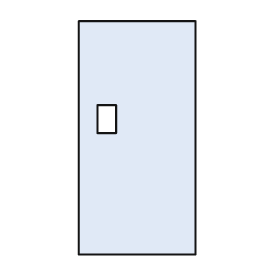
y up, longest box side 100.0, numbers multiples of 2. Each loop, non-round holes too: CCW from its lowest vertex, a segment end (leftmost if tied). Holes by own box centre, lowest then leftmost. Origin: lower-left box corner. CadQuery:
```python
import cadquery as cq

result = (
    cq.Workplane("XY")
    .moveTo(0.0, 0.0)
    .lineTo(50.0, 0.0)
    .lineTo(50.0, 100.0)
    .lineTo(0.0, 100.0)
    .close()
    .moveTo(8.0, 52.0)
    .lineTo(16.0, 52.0)
    .lineTo(16.0, 64.0)
    .lineTo(8.0, 64.0)
    .close()
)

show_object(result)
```